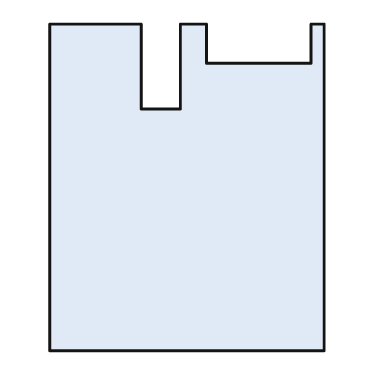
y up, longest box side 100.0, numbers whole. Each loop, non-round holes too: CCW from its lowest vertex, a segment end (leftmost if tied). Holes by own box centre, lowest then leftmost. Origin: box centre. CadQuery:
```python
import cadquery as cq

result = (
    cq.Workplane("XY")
    .moveTo(-42.0, -50.0)
    .lineTo(42.0, -50.0)
    .lineTo(42.0, 50.0)
    .lineTo(38.0, 50.0)
    .lineTo(38.0, 38.0)
    .lineTo(6.0, 38.0)
    .lineTo(6.0, 50.0)
    .lineTo(-2.0, 50.0)
    .lineTo(-2.0, 24.0)
    .lineTo(-14.0, 24.0)
    .lineTo(-14.0, 50.0)
    .lineTo(-42.0, 50.0)
    .close()
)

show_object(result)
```